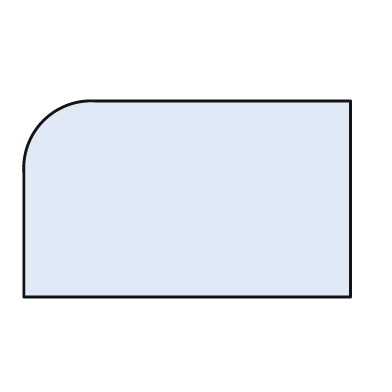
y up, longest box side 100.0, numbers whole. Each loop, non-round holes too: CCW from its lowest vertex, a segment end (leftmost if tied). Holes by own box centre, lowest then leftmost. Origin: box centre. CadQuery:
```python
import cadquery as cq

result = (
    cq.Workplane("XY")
    .moveTo(-50.0, -30.0)
    .lineTo(50.0, -30.0)
    .lineTo(50.0, 30.0)
    .lineTo(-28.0, 30.0)
    .threePointArc((-44.0, 24.0), (-50.0, 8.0))
    .close()
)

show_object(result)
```